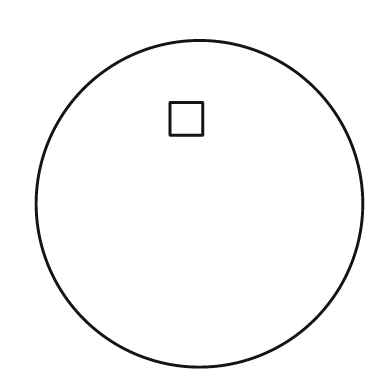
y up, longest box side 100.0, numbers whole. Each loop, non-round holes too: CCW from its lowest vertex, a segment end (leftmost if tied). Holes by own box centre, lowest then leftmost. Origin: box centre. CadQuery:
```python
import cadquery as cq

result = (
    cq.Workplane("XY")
    .moveTo(0.0, 0.0)
    .circle(50.0)
    .moveTo(-9.0, 21.0)
    .lineTo(1.0, 21.0)
    .lineTo(1.0, 31.0)
    .lineTo(-9.0, 31.0)
    .close()
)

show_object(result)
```